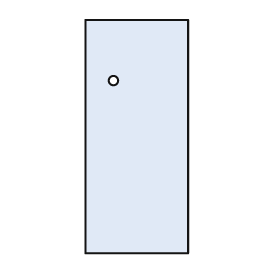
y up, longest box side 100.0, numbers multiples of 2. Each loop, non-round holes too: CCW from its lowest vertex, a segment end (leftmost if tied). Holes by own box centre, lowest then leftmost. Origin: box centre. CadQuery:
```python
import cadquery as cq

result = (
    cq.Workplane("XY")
    .moveTo(-22.0, -50.0)
    .lineTo(22.0, -50.0)
    .lineTo(22.0, 50.0)
    .lineTo(-22.0, 50.0)
    .close()
    .moveTo(-10.0, 24.0)
    .circle(2.0)
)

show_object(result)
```